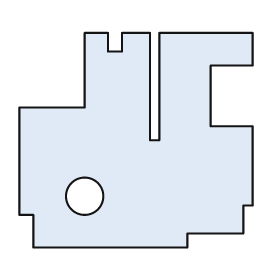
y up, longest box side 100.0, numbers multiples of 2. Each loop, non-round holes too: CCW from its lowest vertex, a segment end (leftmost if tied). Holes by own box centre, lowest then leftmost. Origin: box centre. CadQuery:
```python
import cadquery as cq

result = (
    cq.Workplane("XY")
    .moveTo(-44.0, -46.0)
    .lineTo(22.0, -46.0)
    .lineTo(22.0, -40.0)
    .lineTo(46.0, -40.0)
    .lineTo(46.0, -28.0)
    .lineTo(50.0, -28.0)
    .lineTo(50.0, 6.0)
    .lineTo(32.0, 6.0)
    .lineTo(32.0, 32.0)
    .lineTo(50.0, 32.0)
    .lineTo(50.0, 46.0)
    .lineTo(10.0, 46.0)
    .lineTo(10.0, 0.0)
    .lineTo(6.0, 0.0)
    .lineTo(6.0, 46.0)
    .lineTo(-6.0, 46.0)
    .lineTo(-6.0, 38.0)
    .lineTo(-12.0, 38.0)
    .lineTo(-12.0, 46.0)
    .lineTo(-22.0, 46.0)
    .lineTo(-22.0, 14.0)
    .lineTo(-50.0, 14.0)
    .lineTo(-50.0, -32.0)
    .lineTo(-44.0, -32.0)
    .close()
    .moveTo(-22.0, -24.0)
    .circle(8.0)
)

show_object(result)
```